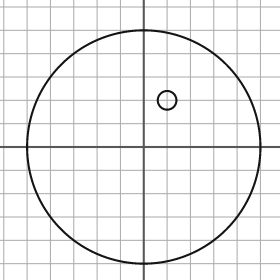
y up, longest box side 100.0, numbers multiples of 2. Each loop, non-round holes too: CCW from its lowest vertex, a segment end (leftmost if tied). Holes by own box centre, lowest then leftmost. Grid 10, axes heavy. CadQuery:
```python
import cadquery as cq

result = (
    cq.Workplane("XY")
    .moveTo(0.0, 0.0)
    .circle(50.0)
    .moveTo(10.0, 20.0)
    .circle(4.0)
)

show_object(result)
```